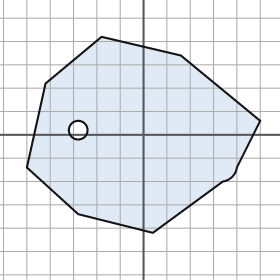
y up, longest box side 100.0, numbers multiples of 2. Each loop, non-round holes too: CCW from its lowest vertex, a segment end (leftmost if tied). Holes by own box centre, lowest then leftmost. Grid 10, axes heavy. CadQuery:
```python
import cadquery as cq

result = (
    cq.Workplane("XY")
    .moveTo(4.0, -42.0)
    .lineTo(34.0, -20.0)
    .threePointArc((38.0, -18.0), (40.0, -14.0))
    .lineTo(50.0, 6.0)
    .lineTo(16.0, 34.0)
    .lineTo(-18.0, 42.0)
    .lineTo(-42.0, 22.0)
    .lineTo(-50.0, -14.0)
    .lineTo(-28.0, -34.0)
    .close()
    .moveTo(-28.0, 2.0)
    .circle(4.0)
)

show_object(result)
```